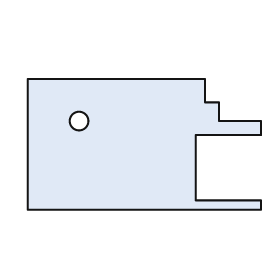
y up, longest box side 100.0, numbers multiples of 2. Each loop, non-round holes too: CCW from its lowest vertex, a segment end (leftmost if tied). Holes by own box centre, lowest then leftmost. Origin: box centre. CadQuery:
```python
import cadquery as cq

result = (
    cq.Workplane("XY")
    .moveTo(-50.0, -28.0)
    .lineTo(50.0, -28.0)
    .lineTo(50.0, -24.0)
    .lineTo(22.0, -24.0)
    .lineTo(22.0, 4.0)
    .lineTo(50.0, 4.0)
    .lineTo(50.0, 10.0)
    .lineTo(32.0, 10.0)
    .lineTo(32.0, 18.0)
    .lineTo(26.0, 18.0)
    .lineTo(26.0, 28.0)
    .lineTo(-50.0, 28.0)
    .close()
    .moveTo(-28.0, 10.0)
    .circle(4.0)
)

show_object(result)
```